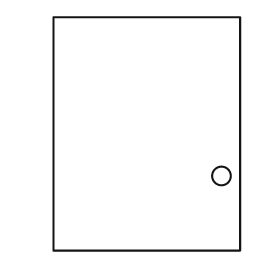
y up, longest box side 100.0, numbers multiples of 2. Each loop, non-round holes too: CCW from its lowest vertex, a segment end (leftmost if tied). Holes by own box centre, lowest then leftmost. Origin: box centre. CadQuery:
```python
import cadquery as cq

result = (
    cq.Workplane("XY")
    .moveTo(-40.0, -50.0)
    .lineTo(40.0, -50.0)
    .lineTo(40.0, 50.0)
    .lineTo(-40.0, 50.0)
    .close()
    .moveTo(32.0, -18.0)
    .circle(4.0)
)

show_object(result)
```